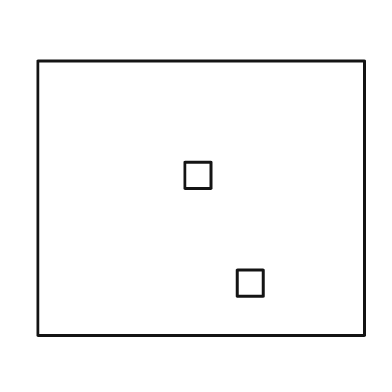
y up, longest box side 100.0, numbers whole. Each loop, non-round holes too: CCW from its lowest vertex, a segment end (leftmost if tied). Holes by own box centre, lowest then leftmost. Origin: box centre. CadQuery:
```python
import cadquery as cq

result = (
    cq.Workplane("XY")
    .moveTo(-50.0, -42.0)
    .lineTo(50.0, -42.0)
    .lineTo(50.0, 42.0)
    .lineTo(-50.0, 42.0)
    .close()
    .moveTo(11.0, -30.0)
    .lineTo(19.0, -30.0)
    .lineTo(19.0, -22.0)
    .lineTo(11.0, -22.0)
    .close()
    .moveTo(-5.0, 3.0)
    .lineTo(3.0, 3.0)
    .lineTo(3.0, 11.0)
    .lineTo(-5.0, 11.0)
    .close()
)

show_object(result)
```